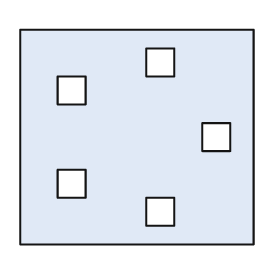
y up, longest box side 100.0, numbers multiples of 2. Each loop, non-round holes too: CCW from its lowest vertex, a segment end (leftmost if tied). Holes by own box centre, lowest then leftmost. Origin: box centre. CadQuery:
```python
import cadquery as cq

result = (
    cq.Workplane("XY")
    .moveTo(-50.0, -46.0)
    .lineTo(50.0, -46.0)
    .lineTo(50.0, 46.0)
    .lineTo(-50.0, 46.0)
    .close()
    .moveTo(4.0, -38.0)
    .lineTo(16.0, -38.0)
    .lineTo(16.0, -26.0)
    .lineTo(4.0, -26.0)
    .close()
    .moveTo(-34.0, -26.0)
    .lineTo(-22.0, -26.0)
    .lineTo(-22.0, -14.0)
    .lineTo(-34.0, -14.0)
    .close()
    .moveTo(28.0, -6.0)
    .lineTo(40.0, -6.0)
    .lineTo(40.0, 6.0)
    .lineTo(28.0, 6.0)
    .close()
    .moveTo(-34.0, 14.0)
    .lineTo(-22.0, 14.0)
    .lineTo(-22.0, 26.0)
    .lineTo(-34.0, 26.0)
    .close()
    .moveTo(4.0, 26.0)
    .lineTo(16.0, 26.0)
    .lineTo(16.0, 38.0)
    .lineTo(4.0, 38.0)
    .close()
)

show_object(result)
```